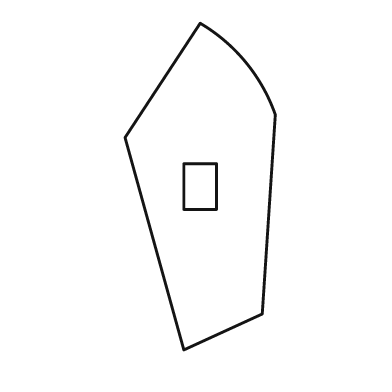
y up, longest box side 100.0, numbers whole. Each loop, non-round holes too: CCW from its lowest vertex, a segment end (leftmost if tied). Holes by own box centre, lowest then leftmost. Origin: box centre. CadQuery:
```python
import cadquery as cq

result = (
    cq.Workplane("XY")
    .moveTo(-5.0, -50.0)
    .lineTo(19.0, -39.0)
    .lineTo(23.0, 22.0)
    .threePointArc((14.0, 38.0), (0.0, 50.0))
    .lineTo(-23.0, 15.0)
    .close()
    .moveTo(-5.0, -7.0)
    .lineTo(5.0, -7.0)
    .lineTo(5.0, 7.0)
    .lineTo(-5.0, 7.0)
    .close()
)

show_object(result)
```